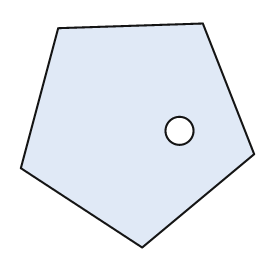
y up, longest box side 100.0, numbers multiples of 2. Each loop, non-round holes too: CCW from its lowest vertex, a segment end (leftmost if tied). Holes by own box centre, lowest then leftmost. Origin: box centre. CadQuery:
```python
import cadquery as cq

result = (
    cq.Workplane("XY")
    .moveTo(2.0, -48.0)
    .lineTo(50.0, -8.0)
    .lineTo(28.0, 48.0)
    .lineTo(-34.0, 46.0)
    .lineTo(-50.0, -14.0)
    .close()
    .moveTo(18.0, 2.0)
    .circle(6.0)
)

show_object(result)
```